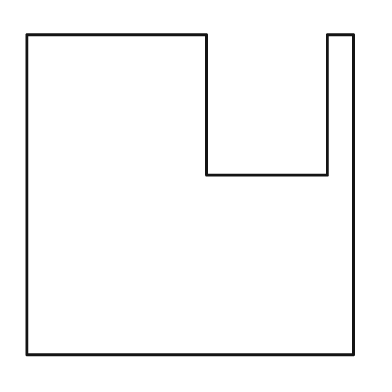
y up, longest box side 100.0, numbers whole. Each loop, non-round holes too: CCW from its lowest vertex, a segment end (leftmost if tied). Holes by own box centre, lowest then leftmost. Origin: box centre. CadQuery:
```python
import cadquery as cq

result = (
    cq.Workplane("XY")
    .moveTo(-50.0, -49.0)
    .lineTo(50.0, -49.0)
    .lineTo(50.0, 49.0)
    .lineTo(42.0, 49.0)
    .lineTo(42.0, 6.0)
    .lineTo(5.0, 6.0)
    .lineTo(5.0, 49.0)
    .lineTo(-50.0, 49.0)
    .close()
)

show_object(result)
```